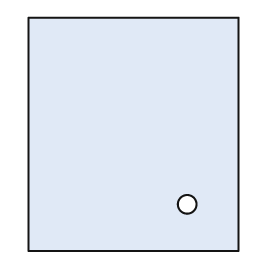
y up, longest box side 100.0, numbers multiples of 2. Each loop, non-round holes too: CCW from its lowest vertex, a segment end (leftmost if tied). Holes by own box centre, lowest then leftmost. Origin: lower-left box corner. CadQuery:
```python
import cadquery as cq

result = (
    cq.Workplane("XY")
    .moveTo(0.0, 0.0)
    .lineTo(90.0, 0.0)
    .lineTo(90.0, 100.0)
    .lineTo(0.0, 100.0)
    .close()
    .moveTo(68.0, 20.0)
    .circle(4.0)
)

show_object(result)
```